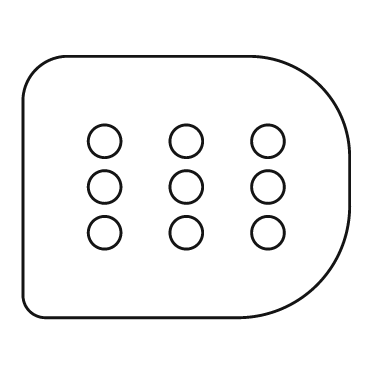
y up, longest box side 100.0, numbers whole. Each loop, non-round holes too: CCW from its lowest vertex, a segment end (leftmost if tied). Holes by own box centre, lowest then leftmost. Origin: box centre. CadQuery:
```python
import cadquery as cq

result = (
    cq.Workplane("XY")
    .moveTo(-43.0, -40.0)
    .lineTo(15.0, -40.0)
    .threePointArc((40.0, -30.0), (50.0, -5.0))
    .lineTo(50.0, 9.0)
    .threePointArc((41.0, 31.0), (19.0, 40.0))
    .lineTo(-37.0, 40.0)
    .threePointArc((-46.0, 36.0), (-50.0, 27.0))
    .lineTo(-50.0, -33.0)
    .threePointArc((-48.0, -38.0), (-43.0, -40.0))
    .close()
    .moveTo(-25.0, -14.0)
    .circle(5.0)
    .moveTo(0.0, -14.0)
    .circle(5.0)
    .moveTo(25.0, -14.0)
    .circle(5.0)
    .moveTo(-25.0, 0.0)
    .circle(5.0)
    .moveTo(0.0, 0.0)
    .circle(5.0)
    .moveTo(25.0, 0.0)
    .circle(5.0)
    .moveTo(-25.0, 14.0)
    .circle(5.0)
    .moveTo(0.0, 14.0)
    .circle(5.0)
    .moveTo(25.0, 14.0)
    .circle(5.0)
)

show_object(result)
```